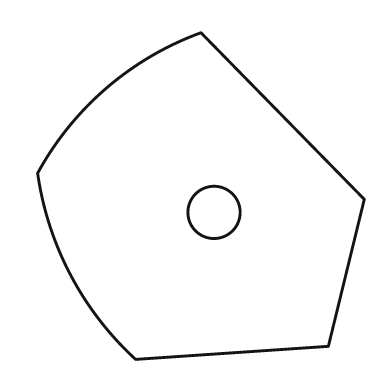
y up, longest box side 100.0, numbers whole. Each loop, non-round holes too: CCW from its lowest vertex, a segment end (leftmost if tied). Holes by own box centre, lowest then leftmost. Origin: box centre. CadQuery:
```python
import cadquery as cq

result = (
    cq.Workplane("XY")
    .moveTo(-20.0, -50.0)
    .lineTo(39.0, -46.0)
    .lineTo(50.0, -1.0)
    .lineTo(0.0, 50.0)
    .threePointArc((-29.0, 33.0), (-50.0, 7.0))
    .threePointArc((-40.0, -24.0), (-20.0, -50.0))
    .close()
    .moveTo(4.0, -5.0)
    .circle(8.0)
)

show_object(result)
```